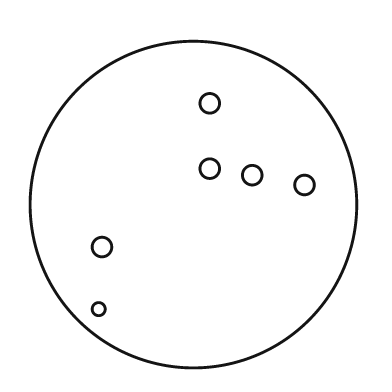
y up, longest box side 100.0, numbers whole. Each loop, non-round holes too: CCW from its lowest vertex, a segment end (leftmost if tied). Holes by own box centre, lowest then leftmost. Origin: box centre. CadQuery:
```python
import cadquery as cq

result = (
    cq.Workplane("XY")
    .moveTo(0.0, 0.0)
    .circle(50.0)
    .moveTo(-29.0, -32.0)
    .circle(2.0)
    .moveTo(-28.0, -13.0)
    .circle(3.0)
    .moveTo(34.0, 6.0)
    .circle(3.0)
    .moveTo(18.0, 9.0)
    .circle(3.0)
    .moveTo(5.0, 11.0)
    .circle(3.0)
    .moveTo(5.0, 31.0)
    .circle(3.0)
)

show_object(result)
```